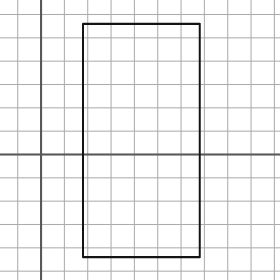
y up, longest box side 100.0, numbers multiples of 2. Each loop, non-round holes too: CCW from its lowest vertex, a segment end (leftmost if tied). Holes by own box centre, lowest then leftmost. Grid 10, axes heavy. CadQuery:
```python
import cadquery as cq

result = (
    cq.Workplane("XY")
    .moveTo(18.0, -44.0)
    .lineTo(68.0, -44.0)
    .lineTo(68.0, 56.0)
    .lineTo(18.0, 56.0)
    .close()
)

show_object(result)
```